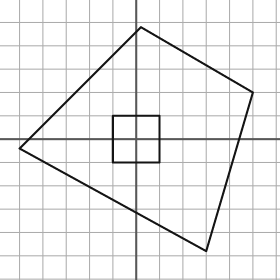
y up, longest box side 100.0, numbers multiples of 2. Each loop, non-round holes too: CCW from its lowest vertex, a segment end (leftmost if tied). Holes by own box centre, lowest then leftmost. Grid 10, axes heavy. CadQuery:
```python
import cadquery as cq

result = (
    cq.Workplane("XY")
    .moveTo(30.0, -48.0)
    .lineTo(50.0, 20.0)
    .lineTo(2.0, 48.0)
    .lineTo(-50.0, -4.0)
    .close()
    .moveTo(-10.0, -10.0)
    .lineTo(10.0, -10.0)
    .lineTo(10.0, 10.0)
    .lineTo(-10.0, 10.0)
    .close()
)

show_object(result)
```